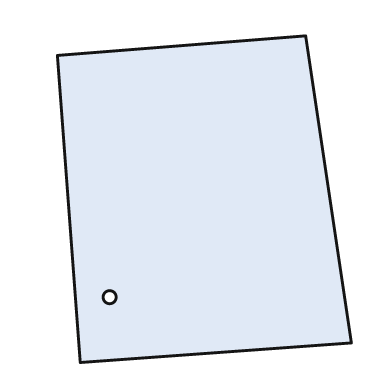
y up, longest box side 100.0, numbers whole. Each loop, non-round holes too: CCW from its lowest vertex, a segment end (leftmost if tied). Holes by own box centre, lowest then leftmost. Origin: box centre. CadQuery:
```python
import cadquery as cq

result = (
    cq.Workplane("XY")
    .moveTo(-38.0, -50.0)
    .lineTo(45.0, -44.0)
    .lineTo(31.0, 50.0)
    .lineTo(-45.0, 44.0)
    .close()
    .moveTo(-29.0, -30.0)
    .circle(2.0)
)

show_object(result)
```